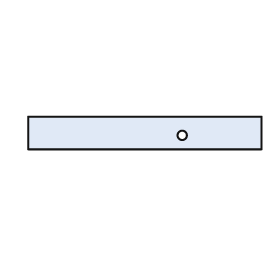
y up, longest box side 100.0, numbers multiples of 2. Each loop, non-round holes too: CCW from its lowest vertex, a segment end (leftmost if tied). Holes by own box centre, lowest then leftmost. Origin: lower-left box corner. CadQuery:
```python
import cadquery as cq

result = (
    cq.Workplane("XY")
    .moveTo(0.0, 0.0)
    .lineTo(100.0, 0.0)
    .lineTo(100.0, 14.0)
    .lineTo(0.0, 14.0)
    .close()
    .moveTo(66.0, 6.0)
    .circle(2.0)
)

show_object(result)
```